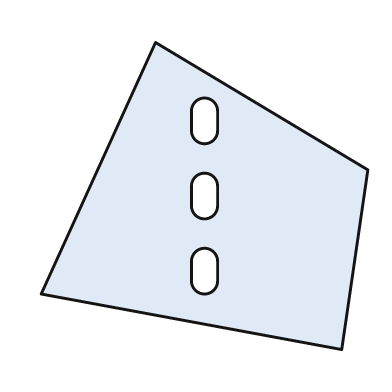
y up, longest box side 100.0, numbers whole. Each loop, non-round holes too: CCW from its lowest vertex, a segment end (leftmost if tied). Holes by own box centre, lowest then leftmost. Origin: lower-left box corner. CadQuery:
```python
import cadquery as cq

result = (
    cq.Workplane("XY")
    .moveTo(92.0, 0.0)
    .lineTo(100.0, 55.0)
    .lineTo(35.0, 94.0)
    .lineTo(0.0, 17.0)
    .close()
    .moveTo(46.0, 21.0)
    .threePointArc((50.0, 17.0), (54.0, 21.0))
    .lineTo(54.0, 27.0)
    .threePointArc((50.0, 31.0), (46.0, 27.0))
    .close()
    .moveTo(46.0, 44.0)
    .threePointArc((50.0, 40.0), (54.0, 44.0))
    .lineTo(54.0, 50.0)
    .threePointArc((50.0, 54.0), (46.0, 50.0))
    .close()
    .moveTo(46.0, 67.0)
    .threePointArc((50.0, 63.0), (54.0, 67.0))
    .lineTo(54.0, 73.0)
    .threePointArc((50.0, 77.0), (46.0, 73.0))
    .close()
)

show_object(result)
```